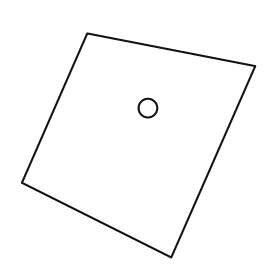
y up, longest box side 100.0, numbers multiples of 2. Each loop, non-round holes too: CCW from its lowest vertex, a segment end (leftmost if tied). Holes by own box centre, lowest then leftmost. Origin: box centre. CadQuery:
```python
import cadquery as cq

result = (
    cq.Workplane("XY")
    .moveTo(14.0, -48.0)
    .lineTo(50.0, 34.0)
    .lineTo(-22.0, 48.0)
    .lineTo(-50.0, -16.0)
    .close()
    .moveTo(4.0, 16.0)
    .circle(4.0)
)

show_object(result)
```